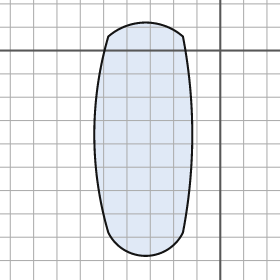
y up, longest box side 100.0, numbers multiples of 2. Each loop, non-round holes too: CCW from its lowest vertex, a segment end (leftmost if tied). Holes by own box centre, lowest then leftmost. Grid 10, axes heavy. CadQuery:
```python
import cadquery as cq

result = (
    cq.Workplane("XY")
    .moveTo(-48.0, -78.0)
    .threePointArc((-32.0, -88.0), (-16.0, -78.0))
    .threePointArc((-12.0, -36.0), (-16.0, 6.0))
    .threePointArc((-32.0, 12.0), (-48.0, 6.0))
    .threePointArc((-54.0, -36.0), (-48.0, -78.0))
    .close()
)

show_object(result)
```